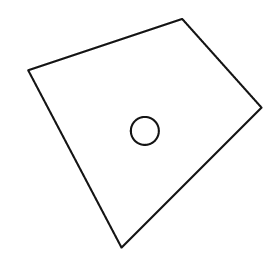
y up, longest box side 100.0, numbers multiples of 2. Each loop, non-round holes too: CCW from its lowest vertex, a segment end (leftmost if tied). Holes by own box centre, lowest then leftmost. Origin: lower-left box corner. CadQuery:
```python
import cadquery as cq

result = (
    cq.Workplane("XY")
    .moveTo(40.0, 0.0)
    .lineTo(100.0, 60.0)
    .lineTo(66.0, 98.0)
    .lineTo(0.0, 76.0)
    .close()
    .moveTo(50.0, 50.0)
    .circle(6.0)
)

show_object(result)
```